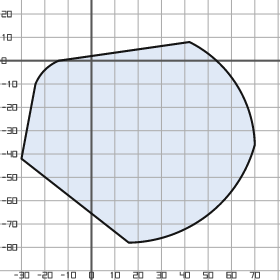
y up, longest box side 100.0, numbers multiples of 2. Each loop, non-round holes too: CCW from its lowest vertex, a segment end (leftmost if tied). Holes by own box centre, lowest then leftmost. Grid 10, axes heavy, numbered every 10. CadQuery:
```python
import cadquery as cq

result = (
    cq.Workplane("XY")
    .moveTo(16.0, -78.0)
    .threePointArc((50.0, -66.0), (70.0, -36.0))
    .threePointArc((62.0, -10.0), (42.0, 8.0))
    .lineTo(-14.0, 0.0)
    .threePointArc((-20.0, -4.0), (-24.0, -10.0))
    .lineTo(-30.0, -42.0)
    .close()
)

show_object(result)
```